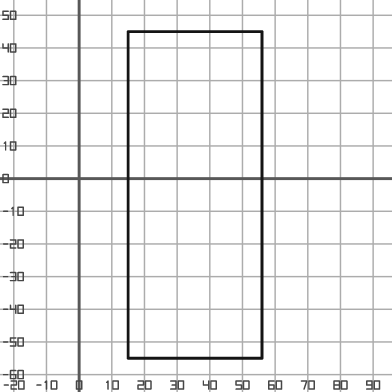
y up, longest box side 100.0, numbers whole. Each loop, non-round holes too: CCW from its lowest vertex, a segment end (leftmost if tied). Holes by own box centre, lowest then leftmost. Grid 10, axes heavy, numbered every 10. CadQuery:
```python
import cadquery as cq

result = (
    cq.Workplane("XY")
    .moveTo(15.0, -55.0)
    .lineTo(56.0, -55.0)
    .lineTo(56.0, 45.0)
    .lineTo(15.0, 45.0)
    .close()
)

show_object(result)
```